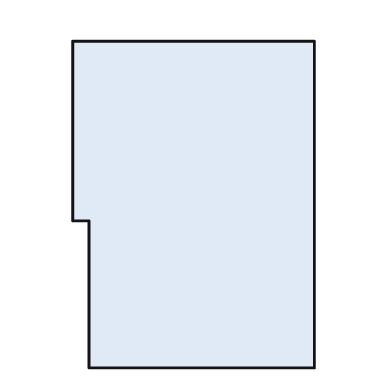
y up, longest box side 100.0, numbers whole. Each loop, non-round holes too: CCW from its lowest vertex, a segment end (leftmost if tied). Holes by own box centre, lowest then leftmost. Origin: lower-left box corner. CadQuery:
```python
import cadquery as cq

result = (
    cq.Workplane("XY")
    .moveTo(5.0, 0.0)
    .lineTo(74.0, 0.0)
    .lineTo(74.0, 100.0)
    .lineTo(0.0, 100.0)
    .lineTo(0.0, 45.0)
    .lineTo(5.0, 45.0)
    .close()
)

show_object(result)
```